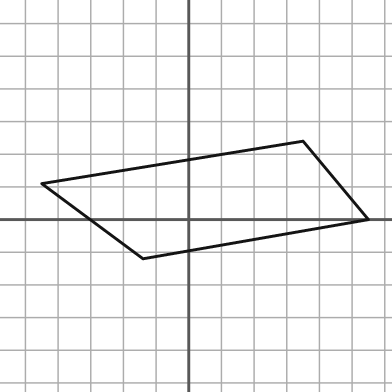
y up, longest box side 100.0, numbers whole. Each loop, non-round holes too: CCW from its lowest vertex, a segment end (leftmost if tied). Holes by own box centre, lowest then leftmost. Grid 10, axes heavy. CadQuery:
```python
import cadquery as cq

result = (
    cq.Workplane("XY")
    .moveTo(-14.0, -12.0)
    .lineTo(55.0, 0.0)
    .lineTo(35.0, 24.0)
    .lineTo(-45.0, 11.0)
    .close()
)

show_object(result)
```